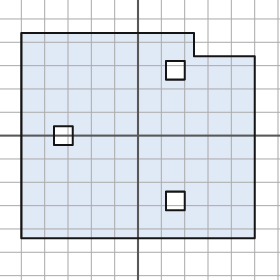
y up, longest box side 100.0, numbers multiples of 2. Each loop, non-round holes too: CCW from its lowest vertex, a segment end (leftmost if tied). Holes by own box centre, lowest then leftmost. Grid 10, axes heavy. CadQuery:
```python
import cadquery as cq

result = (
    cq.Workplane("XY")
    .moveTo(-50.0, -44.0)
    .lineTo(50.0, -44.0)
    .lineTo(50.0, 34.0)
    .lineTo(24.0, 34.0)
    .lineTo(24.0, 44.0)
    .lineTo(-50.0, 44.0)
    .close()
    .moveTo(12.0, -32.0)
    .lineTo(20.0, -32.0)
    .lineTo(20.0, -24.0)
    .lineTo(12.0, -24.0)
    .close()
    .moveTo(-36.0, -4.0)
    .lineTo(-28.0, -4.0)
    .lineTo(-28.0, 4.0)
    .lineTo(-36.0, 4.0)
    .close()
    .moveTo(12.0, 24.0)
    .lineTo(20.0, 24.0)
    .lineTo(20.0, 32.0)
    .lineTo(12.0, 32.0)
    .close()
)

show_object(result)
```